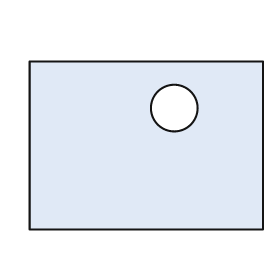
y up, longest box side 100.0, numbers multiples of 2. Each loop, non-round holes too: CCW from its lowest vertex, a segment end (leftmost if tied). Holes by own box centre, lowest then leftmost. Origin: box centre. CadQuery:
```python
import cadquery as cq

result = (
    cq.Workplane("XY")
    .moveTo(-50.0, -36.0)
    .lineTo(50.0, -36.0)
    .lineTo(50.0, 36.0)
    .lineTo(-50.0, 36.0)
    .close()
    .moveTo(12.0, 16.0)
    .circle(10.0)
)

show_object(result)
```